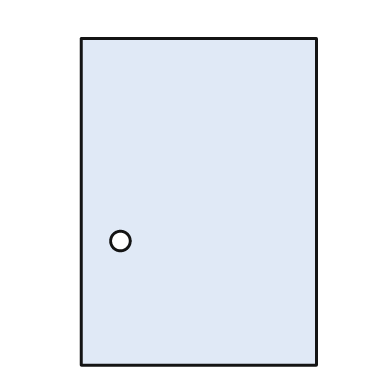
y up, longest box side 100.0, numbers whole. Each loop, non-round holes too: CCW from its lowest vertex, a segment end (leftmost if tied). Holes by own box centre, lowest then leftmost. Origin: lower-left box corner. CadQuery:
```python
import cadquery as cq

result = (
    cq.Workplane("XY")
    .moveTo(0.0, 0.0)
    .lineTo(72.0, 0.0)
    .lineTo(72.0, 100.0)
    .lineTo(0.0, 100.0)
    .close()
    .moveTo(12.0, 38.0)
    .circle(3.0)
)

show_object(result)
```